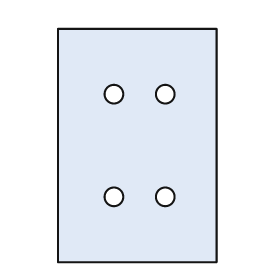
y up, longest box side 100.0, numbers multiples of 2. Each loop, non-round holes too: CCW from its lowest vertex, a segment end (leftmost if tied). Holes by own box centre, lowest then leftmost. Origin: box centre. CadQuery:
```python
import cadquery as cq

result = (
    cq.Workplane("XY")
    .moveTo(-34.0, -50.0)
    .lineTo(34.0, -50.0)
    .lineTo(34.0, 50.0)
    .lineTo(-34.0, 50.0)
    .close()
    .moveTo(-10.0, -22.0)
    .circle(4.0)
    .moveTo(12.0, -22.0)
    .circle(4.0)
    .moveTo(-10.0, 22.0)
    .circle(4.0)
    .moveTo(12.0, 22.0)
    .circle(4.0)
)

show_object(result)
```